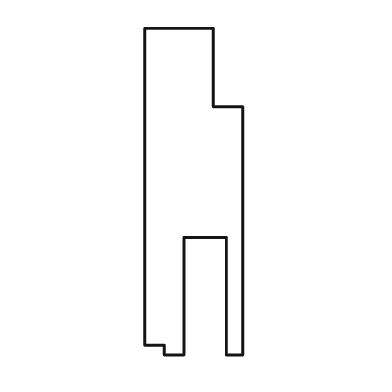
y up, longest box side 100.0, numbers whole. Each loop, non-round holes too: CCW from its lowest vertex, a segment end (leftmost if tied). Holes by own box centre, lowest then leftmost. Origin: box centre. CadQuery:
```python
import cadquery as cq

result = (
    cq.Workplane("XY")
    .moveTo(-9.0, -50.0)
    .lineTo(-3.0, -50.0)
    .lineTo(-3.0, -14.0)
    .lineTo(10.0, -14.0)
    .lineTo(10.0, -50.0)
    .lineTo(15.0, -50.0)
    .lineTo(15.0, 26.0)
    .lineTo(6.0, 26.0)
    .lineTo(6.0, 50.0)
    .lineTo(-15.0, 50.0)
    .lineTo(-15.0, -47.0)
    .lineTo(-9.0, -47.0)
    .close()
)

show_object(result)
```